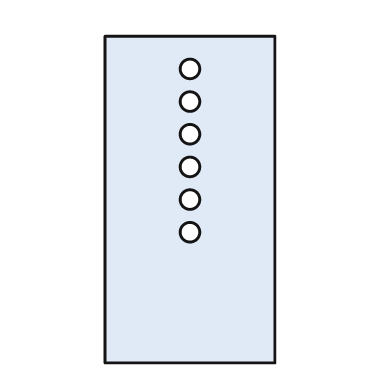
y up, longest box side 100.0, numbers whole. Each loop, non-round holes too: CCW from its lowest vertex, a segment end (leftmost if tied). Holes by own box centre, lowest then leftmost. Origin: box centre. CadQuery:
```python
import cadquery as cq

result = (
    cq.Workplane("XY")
    .moveTo(-26.0, -50.0)
    .lineTo(26.0, -50.0)
    .lineTo(26.0, 50.0)
    .lineTo(-26.0, 50.0)
    .close()
    .moveTo(0.0, -10.0)
    .circle(3.0)
    .moveTo(0.0, 0.0)
    .circle(3.0)
    .moveTo(0.0, 10.0)
    .circle(3.0)
    .moveTo(0.0, 20.0)
    .circle(3.0)
    .moveTo(0.0, 30.0)
    .circle(3.0)
    .moveTo(0.0, 40.0)
    .circle(3.0)
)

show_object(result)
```